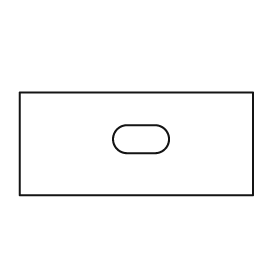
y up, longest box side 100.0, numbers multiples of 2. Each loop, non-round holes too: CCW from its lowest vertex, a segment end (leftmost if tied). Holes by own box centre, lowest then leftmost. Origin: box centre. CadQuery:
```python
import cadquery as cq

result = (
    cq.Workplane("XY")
    .moveTo(-50.0, -22.0)
    .lineTo(50.0, -22.0)
    .lineTo(50.0, 22.0)
    .lineTo(-50.0, 22.0)
    .close()
    .moveTo(-4.0, -4.0)
    .lineTo(8.0, -4.0)
    .threePointArc((14.0, 2.0), (8.0, 8.0))
    .lineTo(-4.0, 8.0)
    .threePointArc((-10.0, 2.0), (-4.0, -4.0))
    .close()
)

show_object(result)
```